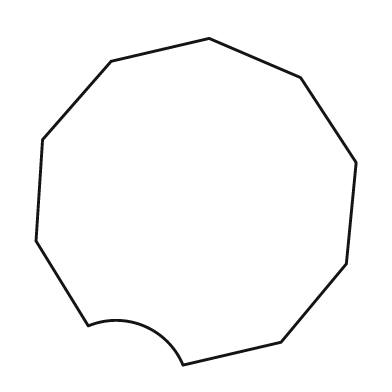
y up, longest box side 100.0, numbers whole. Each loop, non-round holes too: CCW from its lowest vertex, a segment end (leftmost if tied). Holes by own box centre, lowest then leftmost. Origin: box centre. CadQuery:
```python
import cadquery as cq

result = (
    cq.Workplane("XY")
    .moveTo(-4.0, -50.0)
    .lineTo(26.0, -43.0)
    .lineTo(46.0, -19.0)
    .lineTo(49.0, 12.0)
    .lineTo(32.0, 38.0)
    .lineTo(4.0, 50.0)
    .lineTo(-26.0, 43.0)
    .lineTo(-47.0, 19.0)
    .lineTo(-49.0, -12.0)
    .lineTo(-33.0, -38.0)
    .threePointArc((-16.0, -38.0), (-4.0, -50.0))
    .close()
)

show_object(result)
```